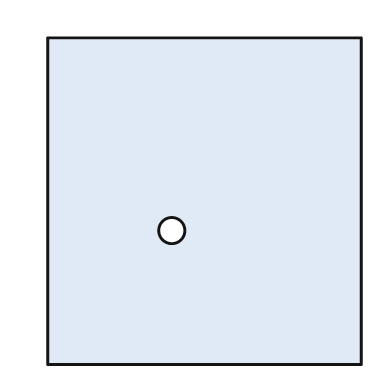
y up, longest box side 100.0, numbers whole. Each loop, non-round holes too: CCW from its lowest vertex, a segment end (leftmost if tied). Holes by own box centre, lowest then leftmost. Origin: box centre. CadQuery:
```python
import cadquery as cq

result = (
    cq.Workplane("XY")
    .moveTo(-48.0, -50.0)
    .lineTo(48.0, -50.0)
    .lineTo(48.0, 50.0)
    .lineTo(-48.0, 50.0)
    .close()
    .moveTo(-10.0, -9.0)
    .circle(4.0)
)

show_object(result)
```